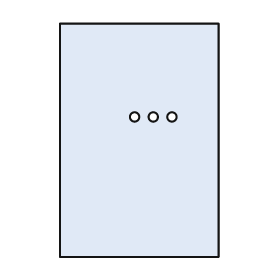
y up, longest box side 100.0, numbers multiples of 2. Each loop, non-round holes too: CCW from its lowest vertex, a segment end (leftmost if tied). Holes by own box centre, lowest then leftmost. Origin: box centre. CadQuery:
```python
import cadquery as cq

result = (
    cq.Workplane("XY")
    .moveTo(-34.0, -50.0)
    .lineTo(34.0, -50.0)
    .lineTo(34.0, 50.0)
    .lineTo(-34.0, 50.0)
    .close()
    .moveTo(-2.0, 10.0)
    .circle(2.0)
    .moveTo(6.0, 10.0)
    .circle(2.0)
    .moveTo(14.0, 10.0)
    .circle(2.0)
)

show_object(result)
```